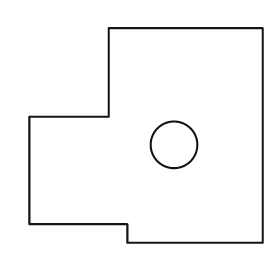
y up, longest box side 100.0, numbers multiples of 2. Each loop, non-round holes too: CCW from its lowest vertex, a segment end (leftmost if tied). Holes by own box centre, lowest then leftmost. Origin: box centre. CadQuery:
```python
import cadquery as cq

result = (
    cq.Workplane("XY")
    .moveTo(-8.0, -46.0)
    .lineTo(50.0, -46.0)
    .lineTo(50.0, 46.0)
    .lineTo(-16.0, 46.0)
    .lineTo(-16.0, 8.0)
    .lineTo(-50.0, 8.0)
    .lineTo(-50.0, -38.0)
    .lineTo(-8.0, -38.0)
    .close()
    .moveTo(12.0, -4.0)
    .circle(10.0)
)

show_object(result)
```